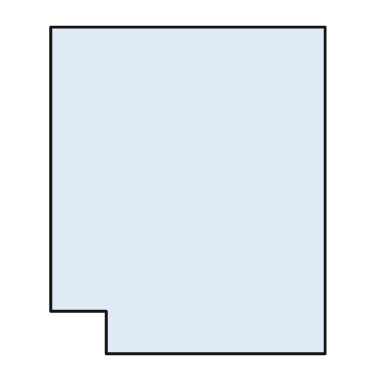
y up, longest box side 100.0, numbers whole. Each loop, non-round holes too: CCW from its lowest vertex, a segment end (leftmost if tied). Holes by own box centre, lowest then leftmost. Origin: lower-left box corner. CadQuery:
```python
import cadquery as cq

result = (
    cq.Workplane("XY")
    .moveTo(17.0, 0.0)
    .lineTo(84.0, 0.0)
    .lineTo(84.0, 100.0)
    .lineTo(0.0, 100.0)
    .lineTo(0.0, 13.0)
    .lineTo(17.0, 13.0)
    .close()
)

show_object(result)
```